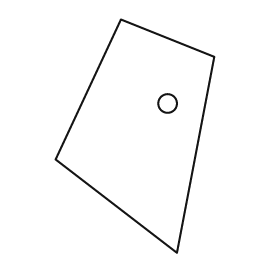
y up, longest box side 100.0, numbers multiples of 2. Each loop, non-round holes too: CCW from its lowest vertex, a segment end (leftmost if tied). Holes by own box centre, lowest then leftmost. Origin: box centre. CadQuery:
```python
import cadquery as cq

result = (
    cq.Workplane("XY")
    .moveTo(18.0, -50.0)
    .lineTo(34.0, 34.0)
    .lineTo(-6.0, 50.0)
    .lineTo(-34.0, -10.0)
    .close()
    .moveTo(14.0, 14.0)
    .circle(4.0)
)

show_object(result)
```